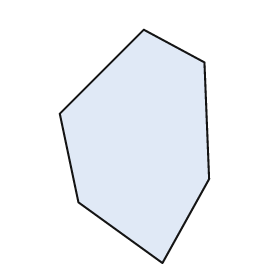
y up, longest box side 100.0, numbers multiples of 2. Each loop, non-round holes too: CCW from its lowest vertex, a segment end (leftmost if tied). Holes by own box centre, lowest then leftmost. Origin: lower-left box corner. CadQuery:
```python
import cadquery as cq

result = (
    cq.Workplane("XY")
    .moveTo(44.0, 0.0)
    .lineTo(64.0, 36.0)
    .lineTo(62.0, 86.0)
    .lineTo(36.0, 100.0)
    .lineTo(0.0, 64.0)
    .lineTo(8.0, 26.0)
    .close()
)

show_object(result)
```